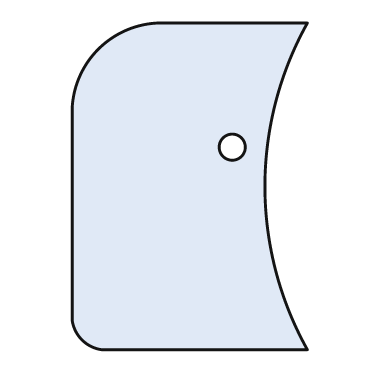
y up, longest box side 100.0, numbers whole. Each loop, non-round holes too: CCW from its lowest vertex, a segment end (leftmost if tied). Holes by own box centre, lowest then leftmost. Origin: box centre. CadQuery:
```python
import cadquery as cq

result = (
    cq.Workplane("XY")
    .moveTo(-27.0, -50.0)
    .lineTo(36.0, -50.0)
    .threePointArc((23.0, 0.0), (36.0, 50.0))
    .lineTo(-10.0, 50.0)
    .threePointArc((-28.0, 42.0), (-36.0, 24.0))
    .lineTo(-36.0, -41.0)
    .threePointArc((-33.0, -47.0), (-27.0, -50.0))
    .close()
    .moveTo(13.0, 12.0)
    .circle(4.0)
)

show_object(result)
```